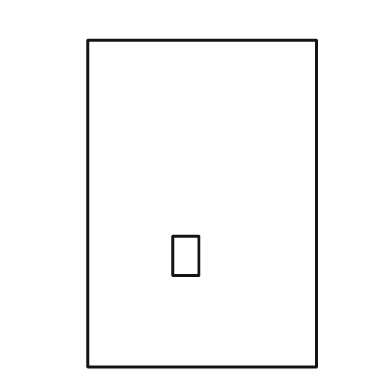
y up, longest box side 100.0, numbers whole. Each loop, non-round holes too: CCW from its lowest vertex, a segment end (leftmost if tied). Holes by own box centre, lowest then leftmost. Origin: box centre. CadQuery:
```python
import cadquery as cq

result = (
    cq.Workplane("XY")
    .moveTo(-35.0, -50.0)
    .lineTo(35.0, -50.0)
    .lineTo(35.0, 50.0)
    .lineTo(-35.0, 50.0)
    .close()
    .moveTo(-9.0, -22.0)
    .lineTo(-1.0, -22.0)
    .lineTo(-1.0, -10.0)
    .lineTo(-9.0, -10.0)
    .close()
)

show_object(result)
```